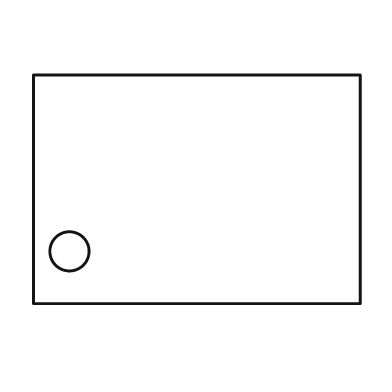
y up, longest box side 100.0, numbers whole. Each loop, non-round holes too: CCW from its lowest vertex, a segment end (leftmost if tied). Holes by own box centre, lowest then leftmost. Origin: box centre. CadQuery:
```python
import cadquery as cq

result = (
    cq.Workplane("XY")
    .moveTo(-50.0, -35.0)
    .lineTo(50.0, -35.0)
    .lineTo(50.0, 35.0)
    .lineTo(-50.0, 35.0)
    .close()
    .moveTo(-39.0, -19.0)
    .circle(6.0)
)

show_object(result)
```